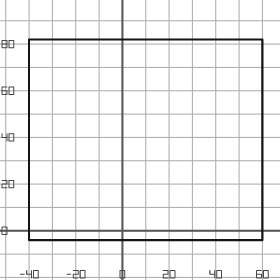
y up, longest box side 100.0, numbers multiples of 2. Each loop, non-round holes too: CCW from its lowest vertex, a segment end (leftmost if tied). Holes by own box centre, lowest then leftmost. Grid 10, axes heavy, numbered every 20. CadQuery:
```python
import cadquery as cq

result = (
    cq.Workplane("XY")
    .moveTo(-40.0, -4.0)
    .lineTo(60.0, -4.0)
    .lineTo(60.0, 82.0)
    .lineTo(-40.0, 82.0)
    .close()
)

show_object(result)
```